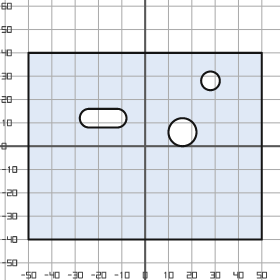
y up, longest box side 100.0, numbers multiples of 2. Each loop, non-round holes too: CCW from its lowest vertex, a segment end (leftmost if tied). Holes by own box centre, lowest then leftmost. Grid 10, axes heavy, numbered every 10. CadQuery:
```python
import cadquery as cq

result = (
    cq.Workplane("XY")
    .moveTo(-50.0, -40.0)
    .lineTo(50.0, -40.0)
    .lineTo(50.0, 40.0)
    .lineTo(-50.0, 40.0)
    .close()
    .moveTo(16.0, 6.0)
    .circle(6.0)
    .moveTo(-24.0, 8.0)
    .lineTo(-12.0, 8.0)
    .threePointArc((-8.0, 12.0), (-12.0, 16.0))
    .lineTo(-24.0, 16.0)
    .threePointArc((-28.0, 12.0), (-24.0, 8.0))
    .close()
    .moveTo(28.0, 28.0)
    .circle(4.0)
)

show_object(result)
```